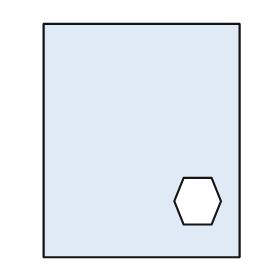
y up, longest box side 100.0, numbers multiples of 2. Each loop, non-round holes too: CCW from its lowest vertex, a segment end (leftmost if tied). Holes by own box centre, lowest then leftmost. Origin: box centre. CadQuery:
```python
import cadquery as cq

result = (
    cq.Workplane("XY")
    .moveTo(-42.0, -50.0)
    .lineTo(42.0, -50.0)
    .lineTo(42.0, 50.0)
    .lineTo(-42.0, 50.0)
    .close()
    .moveTo(18.0, -36.0)
    .lineTo(30.0, -36.0)
    .lineTo(34.0, -26.0)
    .lineTo(30.0, -16.0)
    .lineTo(18.0, -16.0)
    .lineTo(14.0, -26.0)
    .close()
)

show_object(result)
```